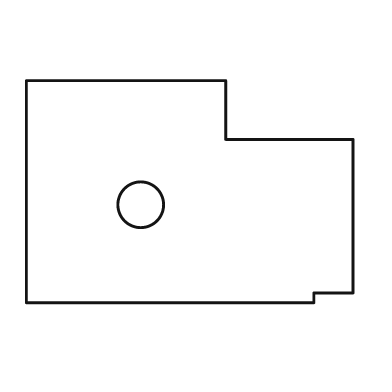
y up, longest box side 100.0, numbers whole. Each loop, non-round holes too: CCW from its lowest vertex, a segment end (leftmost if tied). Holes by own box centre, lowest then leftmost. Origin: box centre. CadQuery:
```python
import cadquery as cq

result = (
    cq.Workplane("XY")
    .moveTo(-50.0, -34.0)
    .lineTo(38.0, -34.0)
    .lineTo(38.0, -31.0)
    .lineTo(50.0, -31.0)
    .lineTo(50.0, 16.0)
    .lineTo(11.0, 16.0)
    .lineTo(11.0, 34.0)
    .lineTo(-50.0, 34.0)
    .close()
    .moveTo(-15.0, -4.0)
    .circle(7.0)
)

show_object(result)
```